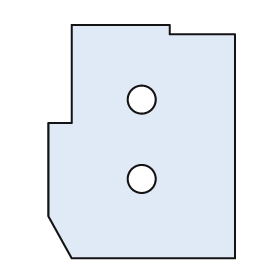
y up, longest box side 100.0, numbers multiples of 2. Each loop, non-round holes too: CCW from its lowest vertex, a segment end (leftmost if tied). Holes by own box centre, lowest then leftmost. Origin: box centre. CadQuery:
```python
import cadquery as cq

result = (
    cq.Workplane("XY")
    .moveTo(-30.0, -50.0)
    .lineTo(40.0, -50.0)
    .lineTo(40.0, 46.0)
    .lineTo(12.0, 46.0)
    .lineTo(12.0, 50.0)
    .lineTo(-30.0, 50.0)
    .lineTo(-30.0, 8.0)
    .lineTo(-40.0, 8.0)
    .lineTo(-40.0, -32.0)
    .close()
    .moveTo(0.0, -16.0)
    .circle(6.0)
    .moveTo(0.0, 18.0)
    .circle(6.0)
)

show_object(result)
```